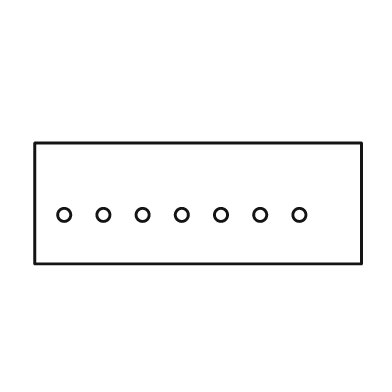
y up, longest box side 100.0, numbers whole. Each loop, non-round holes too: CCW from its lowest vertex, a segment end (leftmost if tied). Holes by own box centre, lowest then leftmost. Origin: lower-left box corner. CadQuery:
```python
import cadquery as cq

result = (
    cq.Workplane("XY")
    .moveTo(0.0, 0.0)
    .lineTo(100.0, 0.0)
    .lineTo(100.0, 37.0)
    .lineTo(0.0, 37.0)
    .close()
    .moveTo(9.0, 15.0)
    .circle(2.0)
    .moveTo(21.0, 15.0)
    .circle(2.0)
    .moveTo(33.0, 15.0)
    .circle(2.0)
    .moveTo(45.0, 15.0)
    .circle(2.0)
    .moveTo(57.0, 15.0)
    .circle(2.0)
    .moveTo(69.0, 15.0)
    .circle(2.0)
    .moveTo(81.0, 15.0)
    .circle(2.0)
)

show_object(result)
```